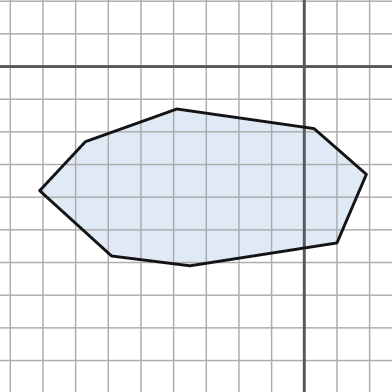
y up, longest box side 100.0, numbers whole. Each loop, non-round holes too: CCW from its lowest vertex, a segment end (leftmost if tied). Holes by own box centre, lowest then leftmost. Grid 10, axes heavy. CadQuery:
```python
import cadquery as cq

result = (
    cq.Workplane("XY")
    .moveTo(-35.0, -61.0)
    .lineTo(10.0, -54.0)
    .lineTo(19.0, -33.0)
    .lineTo(3.0, -19.0)
    .lineTo(-39.0, -13.0)
    .lineTo(-67.0, -23.0)
    .lineTo(-81.0, -38.0)
    .lineTo(-59.0, -58.0)
    .close()
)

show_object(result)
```